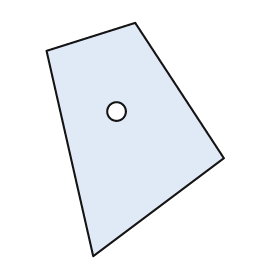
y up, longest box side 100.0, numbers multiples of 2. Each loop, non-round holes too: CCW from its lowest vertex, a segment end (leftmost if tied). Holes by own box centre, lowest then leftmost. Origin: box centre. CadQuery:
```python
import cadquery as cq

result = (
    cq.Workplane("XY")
    .moveTo(-18.0, -50.0)
    .lineTo(38.0, -8.0)
    .lineTo(0.0, 50.0)
    .lineTo(-38.0, 38.0)
    .close()
    .moveTo(-8.0, 12.0)
    .circle(4.0)
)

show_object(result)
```